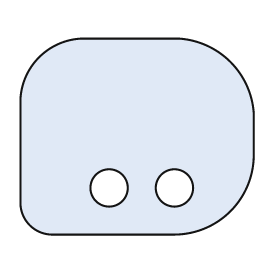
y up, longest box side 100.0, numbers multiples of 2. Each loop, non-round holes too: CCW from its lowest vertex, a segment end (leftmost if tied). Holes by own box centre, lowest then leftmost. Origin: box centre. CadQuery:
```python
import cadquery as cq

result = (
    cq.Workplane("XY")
    .moveTo(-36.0, -42.0)
    .lineTo(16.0, -42.0)
    .threePointArc((40.0, -32.0), (50.0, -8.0))
    .lineTo(50.0, 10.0)
    .threePointArc((40.0, 32.0), (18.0, 42.0))
    .lineTo(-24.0, 42.0)
    .threePointArc((-42.0, 34.0), (-50.0, 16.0))
    .lineTo(-50.0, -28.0)
    .threePointArc((-46.0, -38.0), (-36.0, -42.0))
    .close()
    .moveTo(-12.0, -22.0)
    .circle(8.0)
    .moveTo(16.0, -22.0)
    .circle(8.0)
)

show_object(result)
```